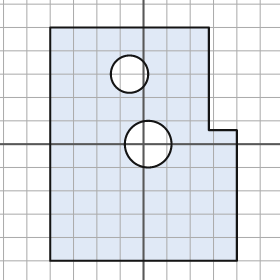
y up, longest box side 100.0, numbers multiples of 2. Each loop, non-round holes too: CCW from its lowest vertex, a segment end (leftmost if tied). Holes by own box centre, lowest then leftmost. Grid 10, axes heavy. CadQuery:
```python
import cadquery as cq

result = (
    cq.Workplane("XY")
    .moveTo(-40.0, -50.0)
    .lineTo(40.0, -50.0)
    .lineTo(40.0, 6.0)
    .lineTo(28.0, 6.0)
    .lineTo(28.0, 50.0)
    .lineTo(-40.0, 50.0)
    .close()
    .moveTo(2.0, 0.0)
    .circle(10.0)
    .moveTo(-6.0, 30.0)
    .circle(8.0)
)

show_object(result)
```